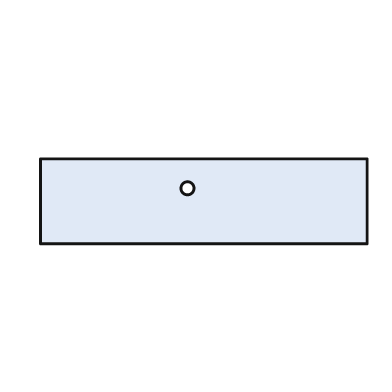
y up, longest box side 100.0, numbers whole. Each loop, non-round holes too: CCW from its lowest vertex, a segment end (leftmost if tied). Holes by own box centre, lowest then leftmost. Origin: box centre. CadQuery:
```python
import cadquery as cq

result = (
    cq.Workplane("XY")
    .moveTo(-50.0, -13.0)
    .lineTo(50.0, -13.0)
    .lineTo(50.0, 13.0)
    .lineTo(-50.0, 13.0)
    .close()
    .moveTo(-5.0, 4.0)
    .circle(2.0)
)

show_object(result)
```